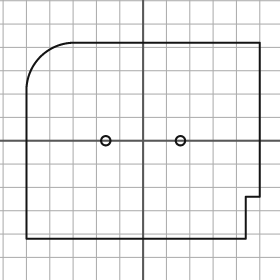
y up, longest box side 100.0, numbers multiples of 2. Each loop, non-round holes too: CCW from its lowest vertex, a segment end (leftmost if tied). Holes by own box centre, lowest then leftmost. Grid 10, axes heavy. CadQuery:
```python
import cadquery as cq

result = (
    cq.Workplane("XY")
    .moveTo(-50.0, -42.0)
    .lineTo(44.0, -42.0)
    .lineTo(44.0, -24.0)
    .lineTo(50.0, -24.0)
    .lineTo(50.0, 42.0)
    .lineTo(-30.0, 42.0)
    .threePointArc((-44.0, 36.0), (-50.0, 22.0))
    .close()
    .moveTo(-16.0, 0.0)
    .circle(2.0)
    .moveTo(16.0, 0.0)
    .circle(2.0)
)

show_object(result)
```